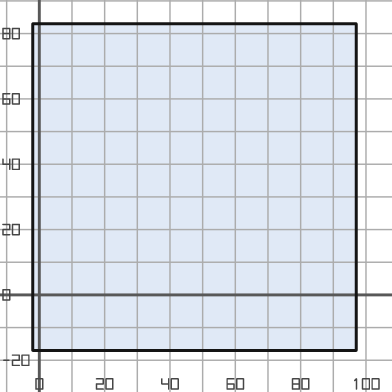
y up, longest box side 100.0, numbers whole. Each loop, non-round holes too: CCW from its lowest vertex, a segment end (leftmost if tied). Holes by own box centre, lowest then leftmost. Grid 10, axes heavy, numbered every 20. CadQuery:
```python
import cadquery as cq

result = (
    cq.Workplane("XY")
    .moveTo(-2.0, -17.0)
    .lineTo(97.0, -17.0)
    .lineTo(97.0, 83.0)
    .lineTo(-2.0, 83.0)
    .close()
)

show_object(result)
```